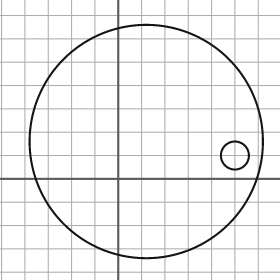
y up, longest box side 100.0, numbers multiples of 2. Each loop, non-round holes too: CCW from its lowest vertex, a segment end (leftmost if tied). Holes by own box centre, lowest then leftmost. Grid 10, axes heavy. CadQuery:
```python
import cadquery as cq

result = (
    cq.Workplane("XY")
    .moveTo(12.0, 16.0)
    .circle(50.0)
    .moveTo(50.0, 10.0)
    .circle(6.0)
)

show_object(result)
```